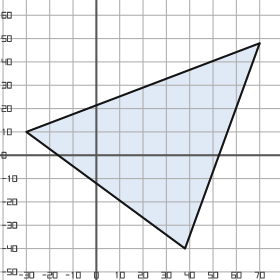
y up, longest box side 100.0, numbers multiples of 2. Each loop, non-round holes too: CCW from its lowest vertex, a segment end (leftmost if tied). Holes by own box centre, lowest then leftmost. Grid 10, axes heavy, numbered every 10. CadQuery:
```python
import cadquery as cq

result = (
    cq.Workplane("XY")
    .moveTo(38.0, -40.0)
    .lineTo(70.0, 48.0)
    .lineTo(-30.0, 10.0)
    .close()
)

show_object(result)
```